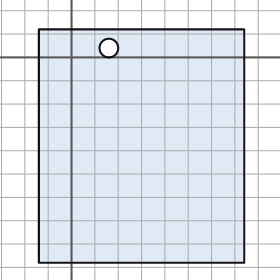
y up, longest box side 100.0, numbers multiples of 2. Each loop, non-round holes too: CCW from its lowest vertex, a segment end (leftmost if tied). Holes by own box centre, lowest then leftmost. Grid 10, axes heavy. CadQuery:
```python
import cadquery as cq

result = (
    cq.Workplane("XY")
    .moveTo(-14.0, -88.0)
    .lineTo(74.0, -88.0)
    .lineTo(74.0, 12.0)
    .lineTo(-14.0, 12.0)
    .close()
    .moveTo(16.0, 4.0)
    .circle(4.0)
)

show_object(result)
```